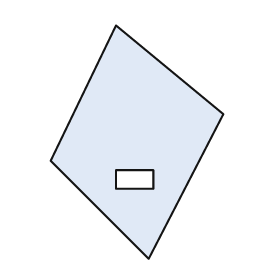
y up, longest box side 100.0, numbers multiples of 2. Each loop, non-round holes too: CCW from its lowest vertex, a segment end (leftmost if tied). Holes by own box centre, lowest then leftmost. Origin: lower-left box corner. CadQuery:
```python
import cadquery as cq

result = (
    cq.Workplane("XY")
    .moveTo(42.0, 0.0)
    .lineTo(74.0, 62.0)
    .lineTo(28.0, 100.0)
    .lineTo(0.0, 42.0)
    .close()
    .moveTo(28.0, 30.0)
    .lineTo(44.0, 30.0)
    .lineTo(44.0, 38.0)
    .lineTo(28.0, 38.0)
    .close()
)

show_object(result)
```